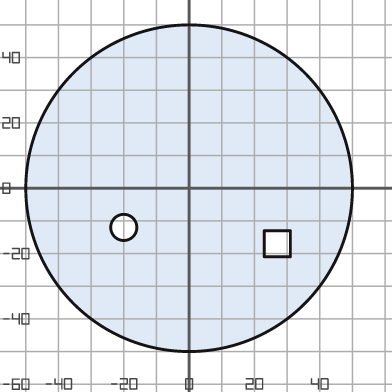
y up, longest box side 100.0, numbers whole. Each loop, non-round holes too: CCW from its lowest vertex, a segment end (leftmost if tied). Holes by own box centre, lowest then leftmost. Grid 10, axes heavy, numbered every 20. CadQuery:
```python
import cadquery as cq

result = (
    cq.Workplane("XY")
    .moveTo(0.0, 0.0)
    .circle(50.0)
    .moveTo(23.0, -21.0)
    .lineTo(31.0, -21.0)
    .lineTo(31.0, -13.0)
    .lineTo(23.0, -13.0)
    .close()
    .moveTo(-20.0, -12.0)
    .circle(4.0)
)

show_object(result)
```